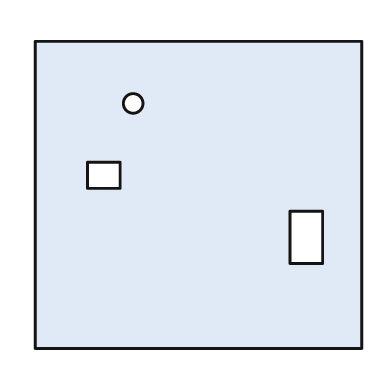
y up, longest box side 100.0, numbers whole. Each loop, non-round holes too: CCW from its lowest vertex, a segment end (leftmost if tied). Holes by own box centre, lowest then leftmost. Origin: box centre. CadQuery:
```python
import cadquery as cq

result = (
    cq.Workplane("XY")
    .moveTo(-50.0, -47.0)
    .lineTo(50.0, -47.0)
    .lineTo(50.0, 47.0)
    .lineTo(-50.0, 47.0)
    .close()
    .moveTo(28.0, -21.0)
    .lineTo(38.0, -21.0)
    .lineTo(38.0, -5.0)
    .lineTo(28.0, -5.0)
    .close()
    .moveTo(-34.0, 2.0)
    .lineTo(-24.0, 2.0)
    .lineTo(-24.0, 10.0)
    .lineTo(-34.0, 10.0)
    .close()
    .moveTo(-20.0, 28.0)
    .circle(3.0)
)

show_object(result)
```